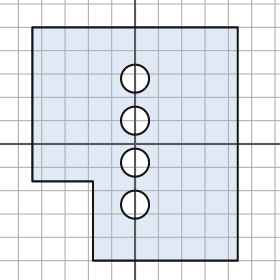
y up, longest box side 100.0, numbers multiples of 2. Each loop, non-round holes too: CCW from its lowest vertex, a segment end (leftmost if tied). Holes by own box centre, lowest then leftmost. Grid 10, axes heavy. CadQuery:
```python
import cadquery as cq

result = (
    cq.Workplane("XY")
    .moveTo(-18.0, -50.0)
    .lineTo(44.0, -50.0)
    .lineTo(44.0, 50.0)
    .lineTo(-44.0, 50.0)
    .lineTo(-44.0, -16.0)
    .lineTo(-18.0, -16.0)
    .close()
    .moveTo(0.0, -26.0)
    .circle(6.0)
    .moveTo(0.0, -8.0)
    .circle(6.0)
    .moveTo(0.0, 10.0)
    .circle(6.0)
    .moveTo(0.0, 28.0)
    .circle(6.0)
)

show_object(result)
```